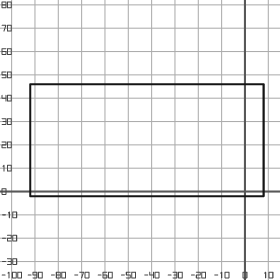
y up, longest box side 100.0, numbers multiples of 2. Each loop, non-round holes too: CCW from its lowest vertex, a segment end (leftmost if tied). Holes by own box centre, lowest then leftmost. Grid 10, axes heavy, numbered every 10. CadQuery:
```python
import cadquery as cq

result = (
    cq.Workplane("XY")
    .moveTo(-92.0, -2.0)
    .lineTo(8.0, -2.0)
    .lineTo(8.0, 46.0)
    .lineTo(-92.0, 46.0)
    .close()
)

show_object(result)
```